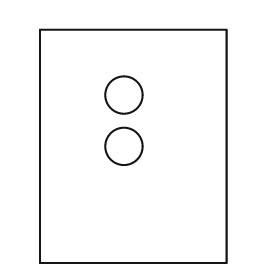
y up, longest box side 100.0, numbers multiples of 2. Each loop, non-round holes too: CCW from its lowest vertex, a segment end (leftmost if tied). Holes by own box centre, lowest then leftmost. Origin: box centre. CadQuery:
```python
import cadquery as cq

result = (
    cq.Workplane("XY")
    .moveTo(-40.0, -50.0)
    .lineTo(40.0, -50.0)
    .lineTo(40.0, 50.0)
    .lineTo(-40.0, 50.0)
    .close()
    .moveTo(-4.0, 0.0)
    .circle(8.0)
    .moveTo(-4.0, 22.0)
    .circle(8.0)
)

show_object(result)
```